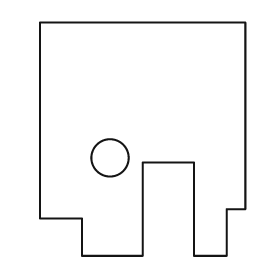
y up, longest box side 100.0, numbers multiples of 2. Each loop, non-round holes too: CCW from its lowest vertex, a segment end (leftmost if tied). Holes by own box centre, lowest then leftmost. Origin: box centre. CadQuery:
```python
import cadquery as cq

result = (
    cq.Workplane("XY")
    .moveTo(-26.0, -50.0)
    .lineTo(0.0, -50.0)
    .lineTo(0.0, -10.0)
    .lineTo(22.0, -10.0)
    .lineTo(22.0, -50.0)
    .lineTo(36.0, -50.0)
    .lineTo(36.0, -30.0)
    .lineTo(44.0, -30.0)
    .lineTo(44.0, 50.0)
    .lineTo(-44.0, 50.0)
    .lineTo(-44.0, -34.0)
    .lineTo(-26.0, -34.0)
    .close()
    .moveTo(-14.0, -8.0)
    .circle(8.0)
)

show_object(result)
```